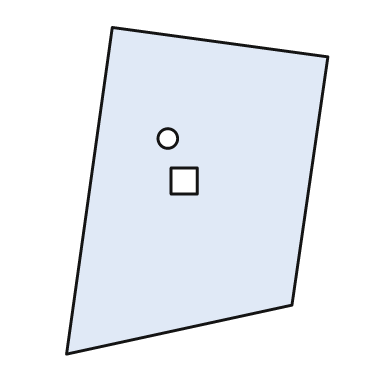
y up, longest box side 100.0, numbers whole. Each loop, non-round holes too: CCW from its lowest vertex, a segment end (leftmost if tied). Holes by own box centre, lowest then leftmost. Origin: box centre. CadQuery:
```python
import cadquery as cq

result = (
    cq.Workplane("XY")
    .moveTo(-40.0, -50.0)
    .lineTo(29.0, -35.0)
    .lineTo(40.0, 41.0)
    .lineTo(-26.0, 50.0)
    .close()
    .moveTo(-8.0, -1.0)
    .lineTo(0.0, -1.0)
    .lineTo(0.0, 7.0)
    .lineTo(-8.0, 7.0)
    .close()
    .moveTo(-9.0, 16.0)
    .circle(3.0)
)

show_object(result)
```